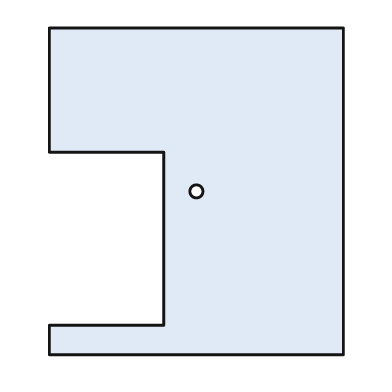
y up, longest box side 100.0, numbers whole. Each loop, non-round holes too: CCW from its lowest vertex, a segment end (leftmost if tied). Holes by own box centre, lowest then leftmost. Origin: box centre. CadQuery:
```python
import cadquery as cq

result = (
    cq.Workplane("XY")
    .moveTo(-45.0, -50.0)
    .lineTo(45.0, -50.0)
    .lineTo(45.0, 50.0)
    .lineTo(-45.0, 50.0)
    .lineTo(-45.0, 12.0)
    .lineTo(-10.0, 12.0)
    .lineTo(-10.0, -41.0)
    .lineTo(-45.0, -41.0)
    .close()
    .moveTo(0.0, 0.0)
    .circle(2.0)
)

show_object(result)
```